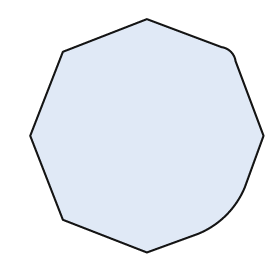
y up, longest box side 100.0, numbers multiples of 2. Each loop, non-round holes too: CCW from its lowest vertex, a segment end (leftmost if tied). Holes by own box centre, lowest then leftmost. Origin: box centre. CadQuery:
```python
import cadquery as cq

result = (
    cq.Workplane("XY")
    .moveTo(0.0, -50.0)
    .lineTo(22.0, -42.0)
    .threePointArc((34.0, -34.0), (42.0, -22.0))
    .lineTo(50.0, 0.0)
    .lineTo(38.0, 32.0)
    .threePointArc((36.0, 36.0), (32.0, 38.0))
    .lineTo(0.0, 50.0)
    .lineTo(-36.0, 36.0)
    .lineTo(-50.0, 0.0)
    .lineTo(-36.0, -36.0)
    .close()
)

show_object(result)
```